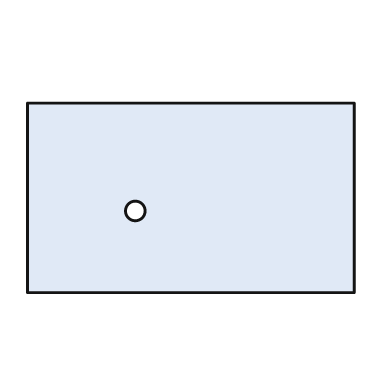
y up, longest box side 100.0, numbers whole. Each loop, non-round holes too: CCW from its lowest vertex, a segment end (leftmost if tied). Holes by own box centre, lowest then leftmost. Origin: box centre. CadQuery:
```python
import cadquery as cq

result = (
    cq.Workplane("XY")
    .moveTo(-50.0, -29.0)
    .lineTo(50.0, -29.0)
    .lineTo(50.0, 29.0)
    .lineTo(-50.0, 29.0)
    .close()
    .moveTo(-17.0, -4.0)
    .circle(3.0)
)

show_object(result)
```